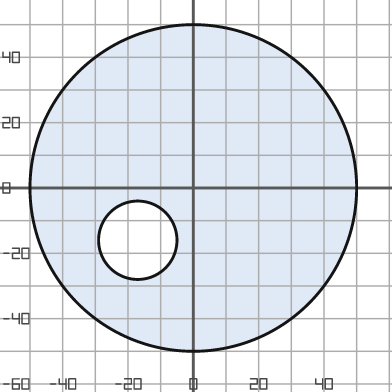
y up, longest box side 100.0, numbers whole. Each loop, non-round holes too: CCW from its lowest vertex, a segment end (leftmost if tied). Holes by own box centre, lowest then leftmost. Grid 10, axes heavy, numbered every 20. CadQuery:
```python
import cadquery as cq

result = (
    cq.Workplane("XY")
    .moveTo(0.0, 0.0)
    .circle(50.0)
    .moveTo(-17.0, -16.0)
    .circle(12.0)
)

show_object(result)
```